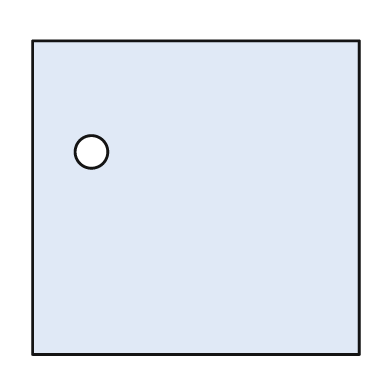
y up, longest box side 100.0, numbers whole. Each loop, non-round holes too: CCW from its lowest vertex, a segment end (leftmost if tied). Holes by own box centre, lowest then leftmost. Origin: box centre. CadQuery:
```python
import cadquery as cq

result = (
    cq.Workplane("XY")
    .moveTo(-50.0, -48.0)
    .lineTo(50.0, -48.0)
    .lineTo(50.0, 48.0)
    .lineTo(-50.0, 48.0)
    .close()
    .moveTo(-32.0, 14.0)
    .circle(5.0)
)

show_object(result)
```